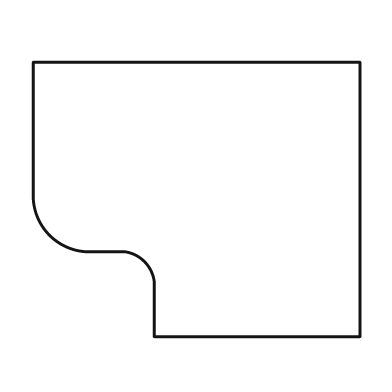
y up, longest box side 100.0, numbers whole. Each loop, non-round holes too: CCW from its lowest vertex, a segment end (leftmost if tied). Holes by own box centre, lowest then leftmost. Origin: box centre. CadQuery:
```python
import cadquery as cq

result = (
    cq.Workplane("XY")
    .moveTo(-13.0, -42.0)
    .lineTo(50.0, -42.0)
    .lineTo(50.0, 42.0)
    .lineTo(-50.0, 42.0)
    .lineTo(-50.0, 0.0)
    .threePointArc((-45.0, -11.0), (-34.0, -16.0))
    .lineTo(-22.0, -16.0)
    .threePointArc((-16.0, -19.0), (-13.0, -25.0))
    .close()
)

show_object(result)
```